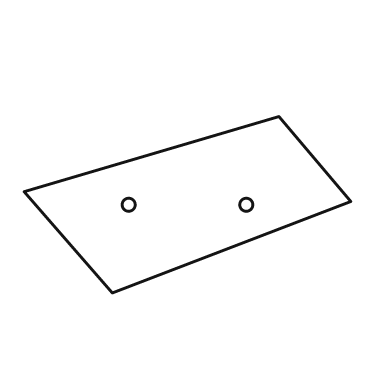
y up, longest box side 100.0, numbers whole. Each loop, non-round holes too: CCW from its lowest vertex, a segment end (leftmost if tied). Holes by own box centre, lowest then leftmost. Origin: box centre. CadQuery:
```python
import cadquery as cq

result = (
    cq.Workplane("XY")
    .moveTo(-23.0, -27.0)
    .lineTo(50.0, 1.0)
    .lineTo(28.0, 27.0)
    .lineTo(-50.0, 4.0)
    .close()
    .moveTo(-18.0, 0.0)
    .circle(2.0)
    .moveTo(18.0, 0.0)
    .circle(2.0)
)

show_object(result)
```